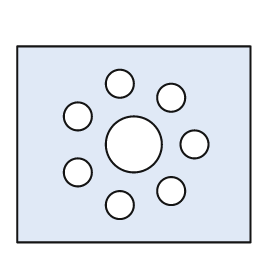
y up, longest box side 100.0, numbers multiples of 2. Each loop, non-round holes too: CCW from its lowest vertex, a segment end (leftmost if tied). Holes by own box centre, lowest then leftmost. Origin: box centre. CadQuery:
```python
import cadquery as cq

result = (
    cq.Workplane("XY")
    .moveTo(-50.0, -42.0)
    .lineTo(50.0, -42.0)
    .lineTo(50.0, 42.0)
    .lineTo(-50.0, 42.0)
    .close()
    .moveTo(-6.0, -26.0)
    .circle(6.0)
    .moveTo(16.0, -20.0)
    .circle(6.0)
    .moveTo(-24.0, -12.0)
    .circle(6.0)
    .moveTo(0.0, 0.0)
    .circle(12.0)
    .moveTo(26.0, 0.0)
    .circle(6.0)
    .moveTo(-24.0, 12.0)
    .circle(6.0)
    .moveTo(16.0, 20.0)
    .circle(6.0)
    .moveTo(-6.0, 26.0)
    .circle(6.0)
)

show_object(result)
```